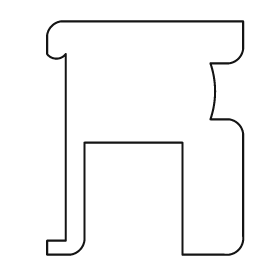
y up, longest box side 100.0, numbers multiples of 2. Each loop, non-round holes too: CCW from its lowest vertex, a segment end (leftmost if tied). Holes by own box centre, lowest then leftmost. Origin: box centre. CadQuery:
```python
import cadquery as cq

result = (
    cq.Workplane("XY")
    .moveTo(-42.0, -50.0)
    .lineTo(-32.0, -50.0)
    .threePointArc((-28.0, -48.0), (-26.0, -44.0))
    .lineTo(-26.0, -2.0)
    .lineTo(16.0, -2.0)
    .lineTo(16.0, -50.0)
    .lineTo(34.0, -50.0)
    .threePointArc((40.0, -48.0), (42.0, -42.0))
    .lineTo(42.0, 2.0)
    .threePointArc((40.0, 6.0), (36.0, 8.0))
    .lineTo(28.0, 8.0)
    .threePointArc((30.0, 20.0), (28.0, 32.0))
    .lineTo(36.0, 32.0)
    .threePointArc((40.0, 34.0), (42.0, 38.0))
    .lineTo(42.0, 50.0)
    .lineTo(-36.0, 50.0)
    .threePointArc((-40.0, 48.0), (-42.0, 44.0))
    .lineTo(-42.0, 36.0)
    .threePointArc((-38.0, 34.0), (-34.0, 36.0))
    .lineTo(-34.0, -44.0)
    .lineTo(-42.0, -44.0)
    .close()
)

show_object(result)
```